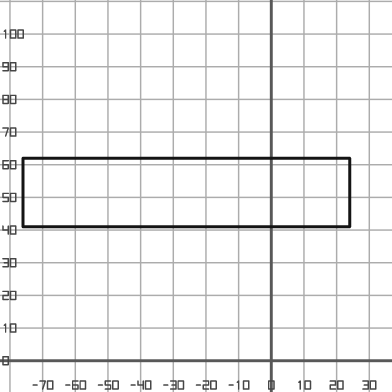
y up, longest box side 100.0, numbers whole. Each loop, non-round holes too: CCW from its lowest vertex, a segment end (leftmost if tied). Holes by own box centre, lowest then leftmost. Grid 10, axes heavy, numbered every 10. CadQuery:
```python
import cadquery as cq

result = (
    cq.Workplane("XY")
    .moveTo(-76.0, 41.0)
    .lineTo(24.0, 41.0)
    .lineTo(24.0, 62.0)
    .lineTo(-76.0, 62.0)
    .close()
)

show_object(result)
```